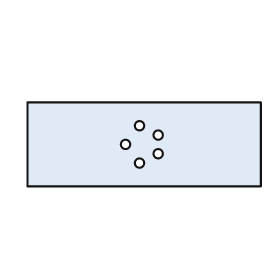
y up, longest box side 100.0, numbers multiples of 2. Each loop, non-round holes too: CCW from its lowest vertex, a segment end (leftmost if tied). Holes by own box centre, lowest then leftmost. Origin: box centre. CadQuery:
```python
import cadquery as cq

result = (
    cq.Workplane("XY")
    .moveTo(-50.0, -18.0)
    .lineTo(50.0, -18.0)
    .lineTo(50.0, 18.0)
    .lineTo(-50.0, 18.0)
    .close()
    .moveTo(-2.0, -8.0)
    .circle(2.0)
    .moveTo(6.0, -4.0)
    .circle(2.0)
    .moveTo(-8.0, 0.0)
    .circle(2.0)
    .moveTo(6.0, 4.0)
    .circle(2.0)
    .moveTo(-2.0, 8.0)
    .circle(2.0)
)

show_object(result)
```